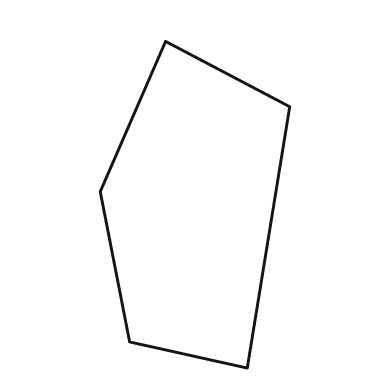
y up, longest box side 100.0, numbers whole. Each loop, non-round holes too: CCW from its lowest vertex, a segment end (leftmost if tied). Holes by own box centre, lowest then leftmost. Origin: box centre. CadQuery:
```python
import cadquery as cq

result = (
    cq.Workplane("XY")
    .moveTo(16.0, -50.0)
    .lineTo(29.0, 30.0)
    .lineTo(-9.0, 50.0)
    .lineTo(-29.0, 4.0)
    .lineTo(-20.0, -42.0)
    .close()
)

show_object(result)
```